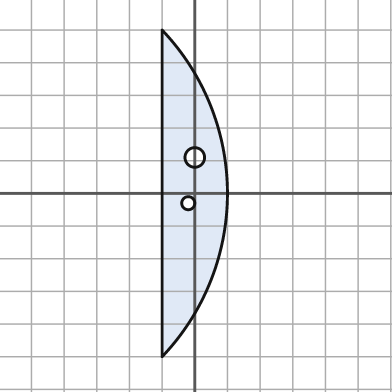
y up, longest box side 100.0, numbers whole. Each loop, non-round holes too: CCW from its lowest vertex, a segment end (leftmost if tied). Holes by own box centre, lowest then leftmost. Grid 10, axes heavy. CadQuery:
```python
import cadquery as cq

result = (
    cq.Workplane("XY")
    .moveTo(-10.0, -50.0)
    .threePointArc((10.0, 0.0), (-10.0, 50.0))
    .close()
    .moveTo(-2.0, -3.0)
    .circle(2.0)
    .moveTo(0.0, 11.0)
    .circle(3.0)
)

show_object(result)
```